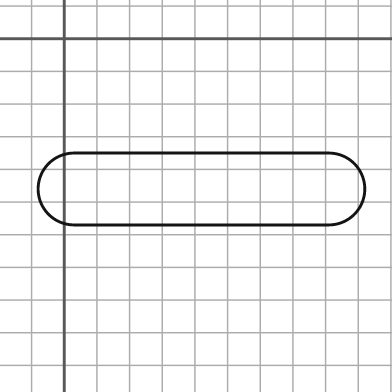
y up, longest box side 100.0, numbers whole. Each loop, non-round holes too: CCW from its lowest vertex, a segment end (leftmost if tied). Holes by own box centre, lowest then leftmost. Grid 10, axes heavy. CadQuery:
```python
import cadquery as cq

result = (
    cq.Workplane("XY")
    .moveTo(3.0, -57.0)
    .lineTo(81.0, -57.0)
    .threePointArc((92.0, -46.0), (81.0, -35.0))
    .lineTo(3.0, -35.0)
    .threePointArc((-8.0, -46.0), (3.0, -57.0))
    .close()
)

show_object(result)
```